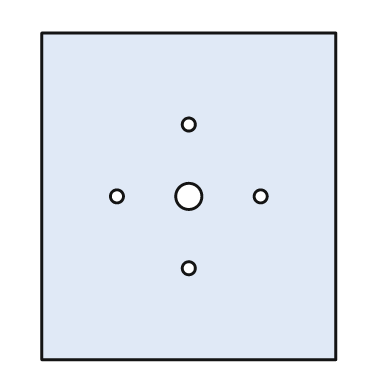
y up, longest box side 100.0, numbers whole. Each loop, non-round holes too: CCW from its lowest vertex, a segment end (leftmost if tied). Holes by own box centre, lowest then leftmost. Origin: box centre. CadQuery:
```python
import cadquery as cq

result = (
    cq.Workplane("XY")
    .moveTo(-45.0, -50.0)
    .lineTo(45.0, -50.0)
    .lineTo(45.0, 50.0)
    .lineTo(-45.0, 50.0)
    .close()
    .moveTo(0.0, -22.0)
    .circle(2.0)
    .moveTo(-22.0, 0.0)
    .circle(2.0)
    .moveTo(0.0, 0.0)
    .circle(4.0)
    .moveTo(22.0, 0.0)
    .circle(2.0)
    .moveTo(0.0, 22.0)
    .circle(2.0)
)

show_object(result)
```